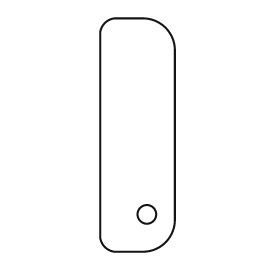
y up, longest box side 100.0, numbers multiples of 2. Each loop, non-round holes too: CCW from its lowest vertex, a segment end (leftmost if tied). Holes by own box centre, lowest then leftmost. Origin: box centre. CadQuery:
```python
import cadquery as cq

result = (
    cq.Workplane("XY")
    .moveTo(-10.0, -50.0)
    .lineTo(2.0, -50.0)
    .threePointArc((12.0, -46.0), (16.0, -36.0))
    .lineTo(16.0, 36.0)
    .threePointArc((12.0, 46.0), (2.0, 50.0))
    .lineTo(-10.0, 50.0)
    .threePointArc((-14.0, 48.0), (-16.0, 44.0))
    .lineTo(-16.0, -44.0)
    .threePointArc((-14.0, -48.0), (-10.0, -50.0))
    .close()
    .moveTo(4.0, -34.0)
    .circle(4.0)
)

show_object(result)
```